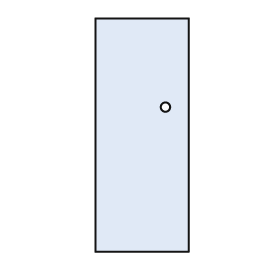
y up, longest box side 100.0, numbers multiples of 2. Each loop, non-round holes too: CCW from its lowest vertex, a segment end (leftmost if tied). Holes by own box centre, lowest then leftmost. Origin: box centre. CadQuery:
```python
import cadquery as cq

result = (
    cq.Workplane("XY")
    .moveTo(-20.0, -50.0)
    .lineTo(20.0, -50.0)
    .lineTo(20.0, 50.0)
    .lineTo(-20.0, 50.0)
    .close()
    .moveTo(10.0, 12.0)
    .circle(2.0)
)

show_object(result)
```